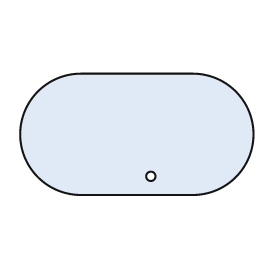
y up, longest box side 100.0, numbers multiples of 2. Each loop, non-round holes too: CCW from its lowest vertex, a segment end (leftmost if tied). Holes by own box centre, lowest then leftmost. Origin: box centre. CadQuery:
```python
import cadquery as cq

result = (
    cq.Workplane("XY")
    .moveTo(-24.0, -26.0)
    .lineTo(24.0, -26.0)
    .threePointArc((50.0, 0.0), (24.0, 26.0))
    .lineTo(-24.0, 26.0)
    .threePointArc((-50.0, 0.0), (-24.0, -26.0))
    .close()
    .moveTo(6.0, -18.0)
    .circle(2.0)
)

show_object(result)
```